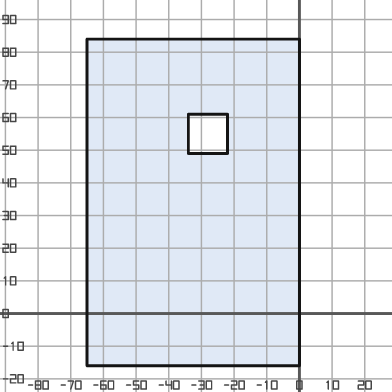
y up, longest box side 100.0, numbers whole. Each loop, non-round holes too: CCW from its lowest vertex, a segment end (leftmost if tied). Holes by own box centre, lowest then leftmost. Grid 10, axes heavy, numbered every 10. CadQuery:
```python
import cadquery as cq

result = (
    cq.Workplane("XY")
    .moveTo(-65.0, -16.0)
    .lineTo(0.0, -16.0)
    .lineTo(0.0, 84.0)
    .lineTo(-65.0, 84.0)
    .close()
    .moveTo(-34.0, 49.0)
    .lineTo(-22.0, 49.0)
    .lineTo(-22.0, 61.0)
    .lineTo(-34.0, 61.0)
    .close()
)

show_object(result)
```